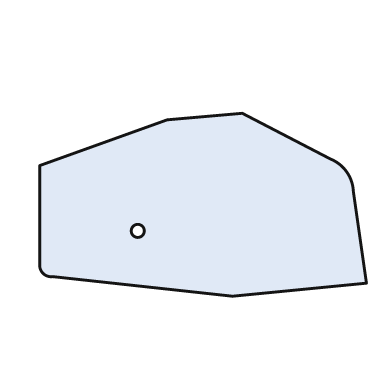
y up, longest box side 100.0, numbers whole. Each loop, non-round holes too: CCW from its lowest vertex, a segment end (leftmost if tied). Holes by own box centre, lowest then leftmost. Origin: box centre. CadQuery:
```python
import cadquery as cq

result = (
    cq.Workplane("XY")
    .moveTo(9.0, -28.0)
    .lineTo(50.0, -24.0)
    .lineTo(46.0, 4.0)
    .threePointArc((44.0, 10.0), (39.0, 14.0))
    .lineTo(12.0, 28.0)
    .lineTo(-11.0, 26.0)
    .lineTo(-50.0, 12.0)
    .lineTo(-50.0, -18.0)
    .threePointArc((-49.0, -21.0), (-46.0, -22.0))
    .close()
    .moveTo(-20.0, -8.0)
    .circle(2.0)
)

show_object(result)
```